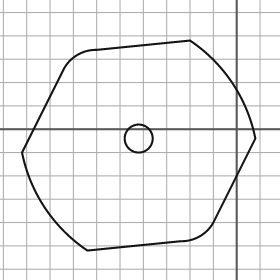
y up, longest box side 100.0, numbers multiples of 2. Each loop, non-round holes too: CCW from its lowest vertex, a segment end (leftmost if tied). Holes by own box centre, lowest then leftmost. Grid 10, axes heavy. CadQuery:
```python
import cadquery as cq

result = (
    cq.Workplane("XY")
    .moveTo(-64.0, -52.0)
    .lineTo(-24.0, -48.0)
    .threePointArc((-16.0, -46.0), (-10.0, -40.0))
    .lineTo(8.0, -4.0)
    .threePointArc((-2.0, 20.0), (-20.0, 38.0))
    .lineTo(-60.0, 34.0)
    .threePointArc((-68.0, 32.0), (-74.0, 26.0))
    .lineTo(-92.0, -10.0)
    .threePointArc((-82.0, -34.0), (-64.0, -52.0))
    .close()
    .moveTo(-42.0, -4.0)
    .circle(6.0)
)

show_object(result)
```